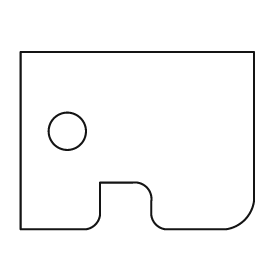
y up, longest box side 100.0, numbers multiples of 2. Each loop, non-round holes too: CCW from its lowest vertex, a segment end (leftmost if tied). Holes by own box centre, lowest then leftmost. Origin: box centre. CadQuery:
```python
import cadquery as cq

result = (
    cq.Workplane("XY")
    .moveTo(-50.0, -38.0)
    .lineTo(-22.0, -38.0)
    .threePointArc((-18.0, -36.0), (-16.0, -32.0))
    .lineTo(-16.0, -18.0)
    .lineTo(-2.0, -18.0)
    .threePointArc((4.0, -20.0), (6.0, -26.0))
    .lineTo(6.0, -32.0)
    .threePointArc((8.0, -36.0), (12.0, -38.0))
    .lineTo(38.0, -38.0)
    .threePointArc((46.0, -34.0), (50.0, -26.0))
    .lineTo(50.0, 38.0)
    .lineTo(-50.0, 38.0)
    .close()
    .moveTo(-30.0, 4.0)
    .circle(8.0)
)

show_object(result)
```